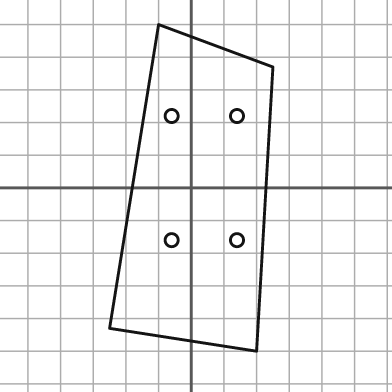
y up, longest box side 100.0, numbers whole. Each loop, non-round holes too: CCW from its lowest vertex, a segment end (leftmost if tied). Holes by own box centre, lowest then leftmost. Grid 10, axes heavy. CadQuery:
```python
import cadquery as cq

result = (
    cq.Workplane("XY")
    .moveTo(20.0, -50.0)
    .lineTo(25.0, 37.0)
    .lineTo(-10.0, 50.0)
    .lineTo(-25.0, -43.0)
    .close()
    .moveTo(-6.0, -16.0)
    .circle(2.0)
    .moveTo(14.0, -16.0)
    .circle(2.0)
    .moveTo(-6.0, 22.0)
    .circle(2.0)
    .moveTo(14.0, 22.0)
    .circle(2.0)
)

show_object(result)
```